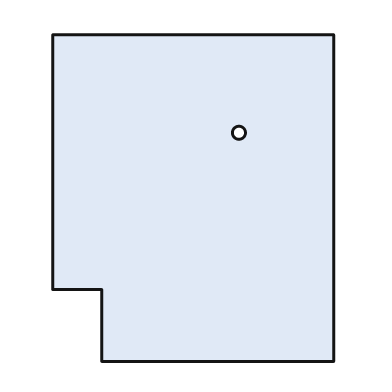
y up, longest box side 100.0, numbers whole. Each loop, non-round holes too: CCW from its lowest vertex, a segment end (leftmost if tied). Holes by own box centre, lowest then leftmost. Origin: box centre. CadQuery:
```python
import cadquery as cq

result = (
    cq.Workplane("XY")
    .moveTo(-28.0, -50.0)
    .lineTo(43.0, -50.0)
    .lineTo(43.0, 50.0)
    .lineTo(-43.0, 50.0)
    .lineTo(-43.0, -28.0)
    .lineTo(-28.0, -28.0)
    .close()
    .moveTo(14.0, 20.0)
    .circle(2.0)
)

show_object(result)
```